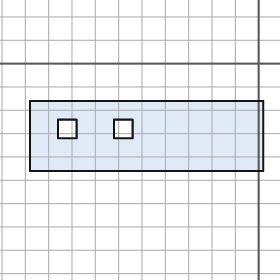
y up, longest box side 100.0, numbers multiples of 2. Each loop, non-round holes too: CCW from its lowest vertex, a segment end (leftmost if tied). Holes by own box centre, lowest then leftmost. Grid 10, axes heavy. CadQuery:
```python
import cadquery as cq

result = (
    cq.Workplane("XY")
    .moveTo(-98.0, -46.0)
    .lineTo(2.0, -46.0)
    .lineTo(2.0, -16.0)
    .lineTo(-98.0, -16.0)
    .close()
    .moveTo(-86.0, -32.0)
    .lineTo(-78.0, -32.0)
    .lineTo(-78.0, -24.0)
    .lineTo(-86.0, -24.0)
    .close()
    .moveTo(-62.0, -32.0)
    .lineTo(-54.0, -32.0)
    .lineTo(-54.0, -24.0)
    .lineTo(-62.0, -24.0)
    .close()
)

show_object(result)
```